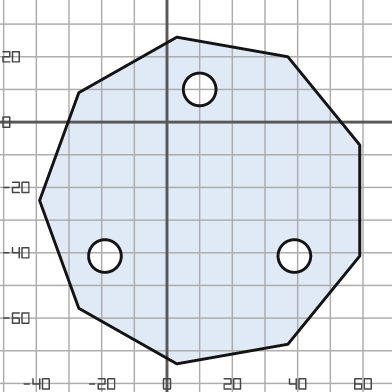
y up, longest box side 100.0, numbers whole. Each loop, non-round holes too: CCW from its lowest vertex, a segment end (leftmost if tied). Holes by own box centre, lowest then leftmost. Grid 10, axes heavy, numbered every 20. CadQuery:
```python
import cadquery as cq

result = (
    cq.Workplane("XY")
    .moveTo(3.0, -74.0)
    .lineTo(37.0, -68.0)
    .lineTo(59.0, -41.0)
    .lineTo(59.0, -7.0)
    .lineTo(37.0, 20.0)
    .lineTo(3.0, 26.0)
    .lineTo(-27.0, 9.0)
    .lineTo(-39.0, -24.0)
    .lineTo(-27.0, -57.0)
    .close()
    .moveTo(-19.0, -41.0)
    .circle(5.0)
    .moveTo(39.0, -41.0)
    .circle(5.0)
    .moveTo(10.0, 10.0)
    .circle(5.0)
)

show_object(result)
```